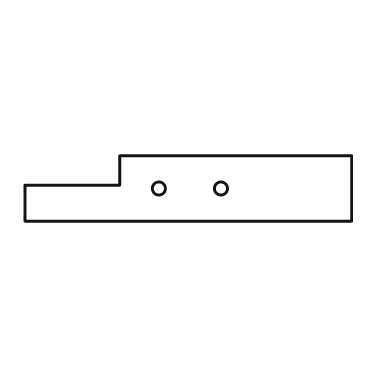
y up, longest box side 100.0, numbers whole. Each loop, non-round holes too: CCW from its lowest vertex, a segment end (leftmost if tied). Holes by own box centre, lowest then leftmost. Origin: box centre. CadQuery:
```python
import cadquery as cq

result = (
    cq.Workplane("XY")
    .moveTo(-50.0, -10.0)
    .lineTo(50.0, -10.0)
    .lineTo(50.0, 10.0)
    .lineTo(-21.0, 10.0)
    .lineTo(-21.0, 1.0)
    .lineTo(-50.0, 1.0)
    .close()
    .moveTo(-9.0, 0.0)
    .circle(2.0)
    .moveTo(10.0, 0.0)
    .circle(2.0)
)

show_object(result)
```